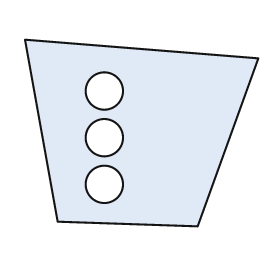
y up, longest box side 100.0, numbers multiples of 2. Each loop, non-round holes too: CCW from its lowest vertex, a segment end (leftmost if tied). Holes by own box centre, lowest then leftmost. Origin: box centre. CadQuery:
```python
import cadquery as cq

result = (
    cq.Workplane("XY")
    .moveTo(24.0, -40.0)
    .lineTo(50.0, 32.0)
    .lineTo(-50.0, 40.0)
    .lineTo(-36.0, -38.0)
    .close()
    .moveTo(-16.0, -22.0)
    .circle(8.0)
    .moveTo(-16.0, -2.0)
    .circle(8.0)
    .moveTo(-16.0, 18.0)
    .circle(8.0)
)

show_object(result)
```